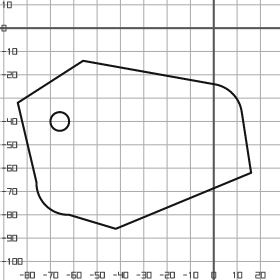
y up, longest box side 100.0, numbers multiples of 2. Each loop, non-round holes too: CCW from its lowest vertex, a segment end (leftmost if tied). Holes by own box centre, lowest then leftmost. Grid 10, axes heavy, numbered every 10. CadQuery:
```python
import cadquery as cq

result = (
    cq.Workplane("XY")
    .moveTo(-42.0, -86.0)
    .lineTo(16.0, -62.0)
    .lineTo(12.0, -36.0)
    .threePointArc((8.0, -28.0), (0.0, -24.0))
    .lineTo(-56.0, -14.0)
    .lineTo(-84.0, -32.0)
    .lineTo(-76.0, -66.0)
    .threePointArc((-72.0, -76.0), (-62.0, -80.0))
    .close()
    .moveTo(-66.0, -40.0)
    .circle(4.0)
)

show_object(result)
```